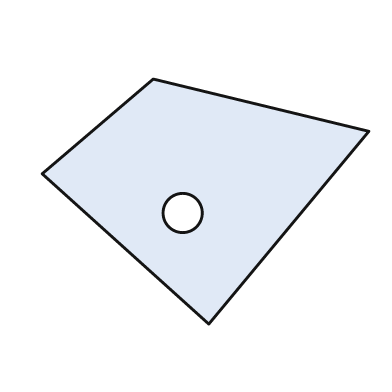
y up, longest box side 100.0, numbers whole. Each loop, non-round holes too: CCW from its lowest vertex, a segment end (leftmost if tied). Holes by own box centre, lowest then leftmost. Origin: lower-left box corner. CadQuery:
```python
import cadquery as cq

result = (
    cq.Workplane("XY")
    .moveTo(51.0, 0.0)
    .lineTo(100.0, 59.0)
    .lineTo(34.0, 75.0)
    .lineTo(0.0, 46.0)
    .close()
    .moveTo(43.0, 34.0)
    .circle(6.0)
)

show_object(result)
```